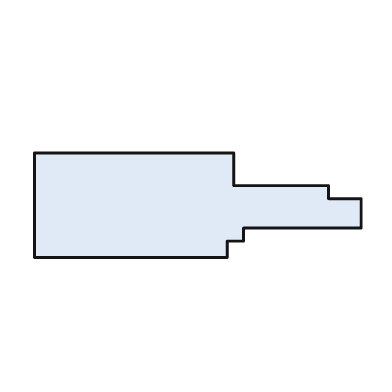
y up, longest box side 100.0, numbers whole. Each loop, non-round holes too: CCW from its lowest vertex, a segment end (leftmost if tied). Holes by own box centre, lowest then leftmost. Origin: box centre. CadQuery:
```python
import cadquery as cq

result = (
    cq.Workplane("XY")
    .moveTo(-50.0, -16.0)
    .lineTo(9.0, -16.0)
    .lineTo(9.0, -11.0)
    .lineTo(14.0, -11.0)
    .lineTo(14.0, -7.0)
    .lineTo(50.0, -7.0)
    .lineTo(50.0, 2.0)
    .lineTo(40.0, 2.0)
    .lineTo(40.0, 6.0)
    .lineTo(11.0, 6.0)
    .lineTo(11.0, 16.0)
    .lineTo(-50.0, 16.0)
    .close()
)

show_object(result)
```